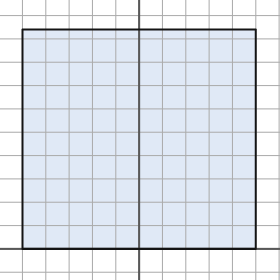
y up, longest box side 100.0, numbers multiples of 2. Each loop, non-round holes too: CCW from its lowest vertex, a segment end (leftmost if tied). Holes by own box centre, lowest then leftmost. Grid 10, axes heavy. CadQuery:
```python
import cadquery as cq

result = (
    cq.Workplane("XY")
    .moveTo(-50.0, 0.0)
    .lineTo(50.0, 0.0)
    .lineTo(50.0, 94.0)
    .lineTo(-50.0, 94.0)
    .close()
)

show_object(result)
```